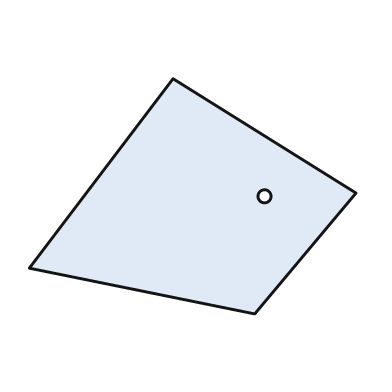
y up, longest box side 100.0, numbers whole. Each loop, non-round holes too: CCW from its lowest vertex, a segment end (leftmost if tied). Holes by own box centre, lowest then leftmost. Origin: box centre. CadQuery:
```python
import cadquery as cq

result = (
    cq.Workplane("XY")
    .moveTo(19.0, -36.0)
    .lineTo(50.0, 1.0)
    .lineTo(-6.0, 36.0)
    .lineTo(-50.0, -22.0)
    .close()
    .moveTo(22.0, 0.0)
    .circle(2.0)
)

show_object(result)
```